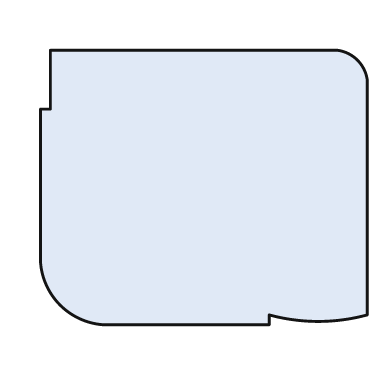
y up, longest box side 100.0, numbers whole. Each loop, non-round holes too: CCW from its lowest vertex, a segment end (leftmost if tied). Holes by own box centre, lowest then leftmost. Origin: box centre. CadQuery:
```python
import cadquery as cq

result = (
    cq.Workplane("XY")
    .moveTo(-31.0, -42.0)
    .lineTo(20.0, -42.0)
    .lineTo(20.0, -39.0)
    .threePointArc((35.0, -41.0), (50.0, -39.0))
    .lineTo(50.0, 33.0)
    .threePointArc((47.0, 39.0), (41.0, 42.0))
    .lineTo(-47.0, 42.0)
    .lineTo(-47.0, 24.0)
    .lineTo(-50.0, 24.0)
    .lineTo(-50.0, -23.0)
    .threePointArc((-44.0, -36.0), (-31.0, -42.0))
    .close()
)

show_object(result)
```